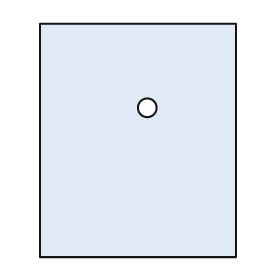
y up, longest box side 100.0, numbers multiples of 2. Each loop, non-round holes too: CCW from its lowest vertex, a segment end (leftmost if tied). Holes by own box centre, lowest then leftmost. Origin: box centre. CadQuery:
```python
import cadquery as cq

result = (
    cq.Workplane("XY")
    .moveTo(-42.0, -50.0)
    .lineTo(42.0, -50.0)
    .lineTo(42.0, 50.0)
    .lineTo(-42.0, 50.0)
    .close()
    .moveTo(4.0, 14.0)
    .circle(4.0)
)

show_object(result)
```